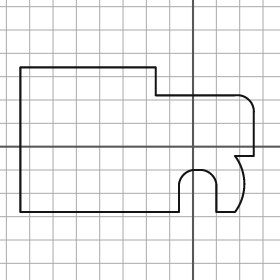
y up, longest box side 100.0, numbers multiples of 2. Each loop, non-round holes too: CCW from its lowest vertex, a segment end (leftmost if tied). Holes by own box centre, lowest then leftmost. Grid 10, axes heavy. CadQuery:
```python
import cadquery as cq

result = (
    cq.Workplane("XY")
    .moveTo(-74.0, -28.0)
    .lineTo(-6.0, -28.0)
    .lineTo(-6.0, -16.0)
    .threePointArc((-4.0, -12.0), (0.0, -10.0))
    .lineTo(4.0, -10.0)
    .threePointArc((8.0, -12.0), (10.0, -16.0))
    .lineTo(10.0, -28.0)
    .lineTo(18.0, -28.0)
    .threePointArc((22.0, -16.0), (18.0, -4.0))
    .lineTo(26.0, -4.0)
    .lineTo(26.0, 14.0)
    .threePointArc((24.0, 20.0), (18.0, 22.0))
    .lineTo(-16.0, 22.0)
    .lineTo(-16.0, 34.0)
    .lineTo(-74.0, 34.0)
    .close()
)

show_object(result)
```